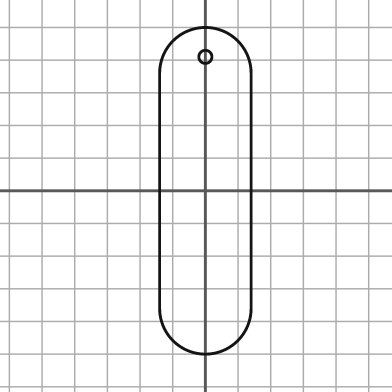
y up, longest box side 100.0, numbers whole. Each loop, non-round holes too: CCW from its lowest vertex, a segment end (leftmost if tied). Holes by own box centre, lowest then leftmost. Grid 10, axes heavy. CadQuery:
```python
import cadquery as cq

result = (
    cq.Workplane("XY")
    .moveTo(-14.0, -36.0)
    .threePointArc((0.0, -50.0), (14.0, -36.0))
    .lineTo(14.0, 36.0)
    .threePointArc((0.0, 50.0), (-14.0, 36.0))
    .close()
    .moveTo(0.0, 41.0)
    .circle(2.0)
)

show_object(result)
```